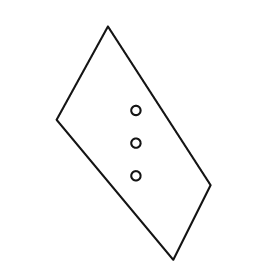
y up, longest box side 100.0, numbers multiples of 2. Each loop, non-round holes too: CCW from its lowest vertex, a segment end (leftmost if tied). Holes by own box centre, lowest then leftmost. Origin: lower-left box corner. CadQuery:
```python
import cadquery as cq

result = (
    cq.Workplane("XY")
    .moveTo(50.0, 0.0)
    .lineTo(66.0, 32.0)
    .lineTo(22.0, 100.0)
    .lineTo(0.0, 60.0)
    .close()
    .moveTo(34.0, 36.0)
    .circle(2.0)
    .moveTo(34.0, 50.0)
    .circle(2.0)
    .moveTo(34.0, 64.0)
    .circle(2.0)
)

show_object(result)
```